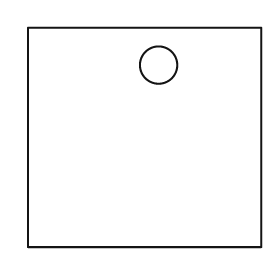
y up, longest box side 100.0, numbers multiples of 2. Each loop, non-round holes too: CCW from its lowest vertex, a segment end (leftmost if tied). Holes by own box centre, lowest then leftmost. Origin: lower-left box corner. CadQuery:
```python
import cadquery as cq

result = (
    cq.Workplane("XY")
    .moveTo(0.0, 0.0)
    .lineTo(100.0, 0.0)
    .lineTo(100.0, 94.0)
    .lineTo(0.0, 94.0)
    .close()
    .moveTo(56.0, 78.0)
    .circle(8.0)
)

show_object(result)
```